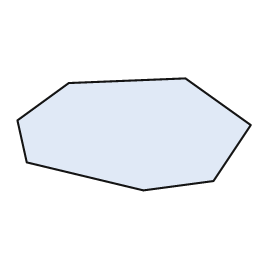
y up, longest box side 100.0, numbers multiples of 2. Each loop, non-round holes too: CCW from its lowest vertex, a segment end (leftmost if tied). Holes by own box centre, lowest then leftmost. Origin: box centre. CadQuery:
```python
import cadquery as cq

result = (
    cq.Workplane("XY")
    .moveTo(4.0, -24.0)
    .lineTo(34.0, -20.0)
    .lineTo(50.0, 4.0)
    .lineTo(22.0, 24.0)
    .lineTo(-28.0, 22.0)
    .lineTo(-50.0, 6.0)
    .lineTo(-46.0, -12.0)
    .close()
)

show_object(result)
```